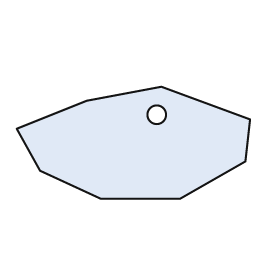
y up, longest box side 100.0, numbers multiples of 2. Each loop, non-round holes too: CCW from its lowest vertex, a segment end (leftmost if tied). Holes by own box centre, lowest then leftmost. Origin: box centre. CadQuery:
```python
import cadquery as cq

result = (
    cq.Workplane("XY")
    .moveTo(-14.0, -24.0)
    .lineTo(20.0, -24.0)
    .lineTo(48.0, -8.0)
    .lineTo(50.0, 10.0)
    .lineTo(12.0, 24.0)
    .lineTo(-20.0, 18.0)
    .lineTo(-50.0, 6.0)
    .lineTo(-40.0, -12.0)
    .close()
    .moveTo(10.0, 12.0)
    .circle(4.0)
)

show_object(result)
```